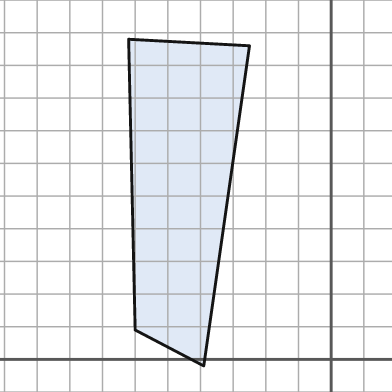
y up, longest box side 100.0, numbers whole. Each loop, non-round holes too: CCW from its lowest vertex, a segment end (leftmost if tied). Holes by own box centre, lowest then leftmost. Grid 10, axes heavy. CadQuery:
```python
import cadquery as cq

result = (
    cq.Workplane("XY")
    .moveTo(-39.0, -2.0)
    .lineTo(-25.0, 96.0)
    .lineTo(-62.0, 98.0)
    .lineTo(-60.0, 9.0)
    .close()
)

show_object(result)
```